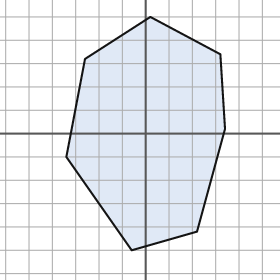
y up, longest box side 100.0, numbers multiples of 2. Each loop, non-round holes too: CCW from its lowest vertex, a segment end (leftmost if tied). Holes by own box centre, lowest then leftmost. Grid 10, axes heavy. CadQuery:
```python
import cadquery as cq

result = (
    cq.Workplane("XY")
    .moveTo(-6.0, -50.0)
    .lineTo(22.0, -42.0)
    .lineTo(34.0, 2.0)
    .lineTo(32.0, 34.0)
    .lineTo(2.0, 50.0)
    .lineTo(-26.0, 32.0)
    .lineTo(-34.0, -10.0)
    .close()
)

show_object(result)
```